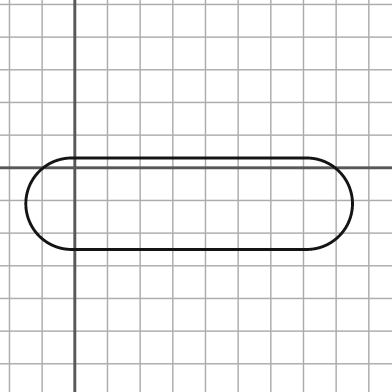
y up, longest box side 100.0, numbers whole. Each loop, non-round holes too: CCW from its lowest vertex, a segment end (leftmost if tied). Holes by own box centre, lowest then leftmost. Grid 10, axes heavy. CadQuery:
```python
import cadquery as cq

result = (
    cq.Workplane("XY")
    .moveTo(-1.0, -25.0)
    .lineTo(71.0, -25.0)
    .threePointArc((85.0, -11.0), (71.0, 3.0))
    .lineTo(-1.0, 3.0)
    .threePointArc((-15.0, -11.0), (-1.0, -25.0))
    .close()
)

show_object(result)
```